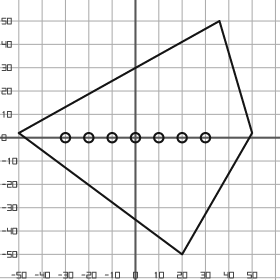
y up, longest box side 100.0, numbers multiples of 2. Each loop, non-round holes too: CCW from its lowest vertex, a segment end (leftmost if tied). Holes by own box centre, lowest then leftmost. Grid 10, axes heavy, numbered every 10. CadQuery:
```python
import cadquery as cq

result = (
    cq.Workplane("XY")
    .moveTo(20.0, -50.0)
    .lineTo(50.0, 2.0)
    .lineTo(36.0, 50.0)
    .lineTo(-50.0, 2.0)
    .close()
    .moveTo(-30.0, 0.0)
    .circle(2.0)
    .moveTo(-20.0, 0.0)
    .circle(2.0)
    .moveTo(-10.0, 0.0)
    .circle(2.0)
    .moveTo(0.0, 0.0)
    .circle(2.0)
    .moveTo(10.0, 0.0)
    .circle(2.0)
    .moveTo(20.0, 0.0)
    .circle(2.0)
    .moveTo(30.0, 0.0)
    .circle(2.0)
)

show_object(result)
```